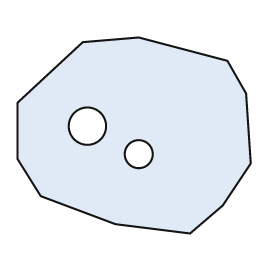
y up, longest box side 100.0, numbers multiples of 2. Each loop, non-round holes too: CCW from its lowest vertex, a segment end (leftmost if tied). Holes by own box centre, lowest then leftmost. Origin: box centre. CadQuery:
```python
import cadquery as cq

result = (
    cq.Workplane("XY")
    .moveTo(24.0, -42.0)
    .lineTo(38.0, -30.0)
    .lineTo(50.0, -12.0)
    .lineTo(48.0, 18.0)
    .lineTo(40.0, 32.0)
    .lineTo(2.0, 42.0)
    .lineTo(-22.0, 40.0)
    .lineTo(-50.0, 14.0)
    .lineTo(-50.0, -10.0)
    .lineTo(-40.0, -26.0)
    .lineTo(-8.0, -38.0)
    .close()
    .moveTo(2.0, -8.0)
    .circle(6.0)
    .moveTo(-20.0, 4.0)
    .circle(8.0)
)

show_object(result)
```